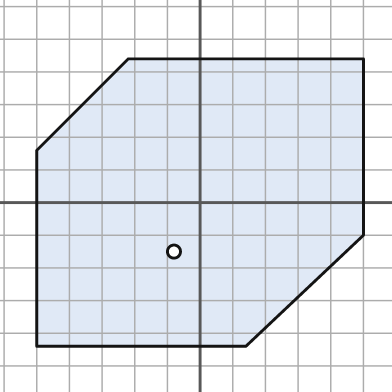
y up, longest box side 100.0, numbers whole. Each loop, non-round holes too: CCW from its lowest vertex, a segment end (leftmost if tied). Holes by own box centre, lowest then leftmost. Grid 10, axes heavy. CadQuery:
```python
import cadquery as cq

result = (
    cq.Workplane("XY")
    .moveTo(-50.0, -44.0)
    .lineTo(14.0, -44.0)
    .lineTo(50.0, -10.0)
    .lineTo(50.0, 44.0)
    .lineTo(-22.0, 44.0)
    .lineTo(-50.0, 16.0)
    .close()
    .moveTo(-8.0, -15.0)
    .circle(2.0)
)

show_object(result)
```